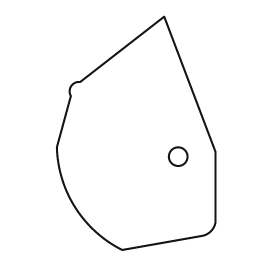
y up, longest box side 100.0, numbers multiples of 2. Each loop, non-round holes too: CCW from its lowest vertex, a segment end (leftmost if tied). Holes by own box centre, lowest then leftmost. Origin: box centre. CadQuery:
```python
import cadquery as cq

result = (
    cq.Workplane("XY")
    .moveTo(-6.0, -50.0)
    .lineTo(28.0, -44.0)
    .threePointArc((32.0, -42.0), (34.0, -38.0))
    .lineTo(34.0, -8.0)
    .lineTo(12.0, 50.0)
    .lineTo(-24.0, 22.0)
    .threePointArc((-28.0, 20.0), (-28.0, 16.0))
    .lineTo(-34.0, -6.0)
    .threePointArc((-26.0, -32.0), (-6.0, -50.0))
    .close()
    .moveTo(18.0, -10.0)
    .circle(4.0)
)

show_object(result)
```